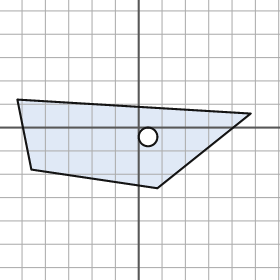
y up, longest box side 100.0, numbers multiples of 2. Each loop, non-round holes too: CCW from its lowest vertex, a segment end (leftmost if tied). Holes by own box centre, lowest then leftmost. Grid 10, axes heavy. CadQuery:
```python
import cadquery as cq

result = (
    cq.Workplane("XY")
    .moveTo(8.0, -26.0)
    .lineTo(48.0, 6.0)
    .lineTo(-52.0, 12.0)
    .lineTo(-46.0, -18.0)
    .close()
    .moveTo(4.0, -4.0)
    .circle(4.0)
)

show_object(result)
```